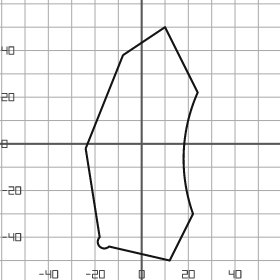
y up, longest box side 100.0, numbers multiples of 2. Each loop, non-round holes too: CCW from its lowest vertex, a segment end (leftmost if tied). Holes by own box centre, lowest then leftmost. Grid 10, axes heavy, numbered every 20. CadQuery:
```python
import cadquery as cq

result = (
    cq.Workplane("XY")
    .moveTo(12.0, -50.0)
    .lineTo(22.0, -30.0)
    .threePointArc((18.0, -4.0), (24.0, 22.0))
    .lineTo(10.0, 50.0)
    .lineTo(-8.0, 38.0)
    .lineTo(-24.0, -2.0)
    .lineTo(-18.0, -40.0)
    .threePointArc((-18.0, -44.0), (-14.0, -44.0))
    .close()
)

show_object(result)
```